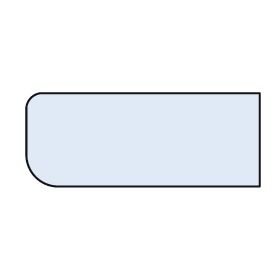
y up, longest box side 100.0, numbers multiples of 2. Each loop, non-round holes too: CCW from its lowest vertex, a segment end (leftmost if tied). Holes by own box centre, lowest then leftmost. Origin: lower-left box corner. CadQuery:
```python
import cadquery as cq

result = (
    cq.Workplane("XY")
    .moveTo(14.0, 0.0)
    .lineTo(100.0, 0.0)
    .lineTo(100.0, 40.0)
    .lineTo(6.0, 40.0)
    .threePointArc((2.0, 38.0), (0.0, 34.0))
    .lineTo(0.0, 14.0)
    .threePointArc((4.0, 4.0), (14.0, 0.0))
    .close()
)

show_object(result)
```